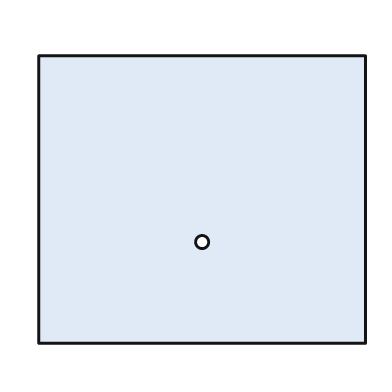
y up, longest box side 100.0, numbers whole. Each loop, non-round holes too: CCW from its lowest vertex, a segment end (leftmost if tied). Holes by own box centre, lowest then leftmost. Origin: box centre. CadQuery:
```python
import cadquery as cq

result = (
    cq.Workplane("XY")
    .moveTo(-50.0, -44.0)
    .lineTo(50.0, -44.0)
    .lineTo(50.0, 44.0)
    .lineTo(-50.0, 44.0)
    .close()
    .moveTo(0.0, -13.0)
    .circle(2.0)
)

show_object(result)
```